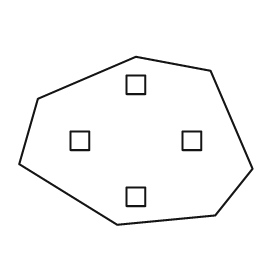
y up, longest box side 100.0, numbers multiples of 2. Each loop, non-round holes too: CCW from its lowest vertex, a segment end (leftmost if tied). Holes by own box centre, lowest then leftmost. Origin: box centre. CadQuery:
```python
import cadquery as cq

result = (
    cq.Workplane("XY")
    .moveTo(-8.0, -36.0)
    .lineTo(34.0, -32.0)
    .lineTo(50.0, -12.0)
    .lineTo(32.0, 30.0)
    .lineTo(0.0, 36.0)
    .lineTo(-42.0, 18.0)
    .lineTo(-50.0, -10.0)
    .close()
    .moveTo(-4.0, -28.0)
    .lineTo(4.0, -28.0)
    .lineTo(4.0, -20.0)
    .lineTo(-4.0, -20.0)
    .close()
    .moveTo(-28.0, -4.0)
    .lineTo(-20.0, -4.0)
    .lineTo(-20.0, 4.0)
    .lineTo(-28.0, 4.0)
    .close()
    .moveTo(20.0, -4.0)
    .lineTo(28.0, -4.0)
    .lineTo(28.0, 4.0)
    .lineTo(20.0, 4.0)
    .close()
    .moveTo(-4.0, 20.0)
    .lineTo(4.0, 20.0)
    .lineTo(4.0, 28.0)
    .lineTo(-4.0, 28.0)
    .close()
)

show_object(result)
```